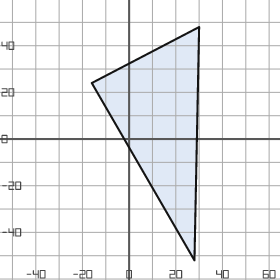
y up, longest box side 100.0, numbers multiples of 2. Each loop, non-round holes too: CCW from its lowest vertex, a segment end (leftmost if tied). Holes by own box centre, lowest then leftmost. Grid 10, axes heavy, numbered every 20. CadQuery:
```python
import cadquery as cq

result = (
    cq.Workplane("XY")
    .moveTo(28.0, -52.0)
    .lineTo(30.0, 48.0)
    .lineTo(-16.0, 24.0)
    .close()
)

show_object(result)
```